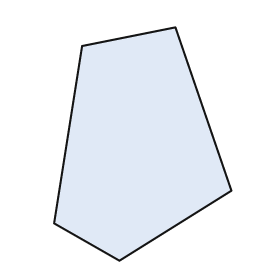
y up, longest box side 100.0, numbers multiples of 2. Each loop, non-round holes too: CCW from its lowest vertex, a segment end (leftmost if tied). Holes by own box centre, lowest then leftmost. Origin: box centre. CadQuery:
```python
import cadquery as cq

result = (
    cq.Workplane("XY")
    .moveTo(-10.0, -50.0)
    .lineTo(38.0, -20.0)
    .lineTo(14.0, 50.0)
    .lineTo(-26.0, 42.0)
    .lineTo(-38.0, -34.0)
    .close()
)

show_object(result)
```